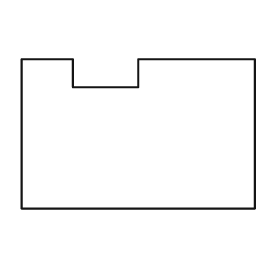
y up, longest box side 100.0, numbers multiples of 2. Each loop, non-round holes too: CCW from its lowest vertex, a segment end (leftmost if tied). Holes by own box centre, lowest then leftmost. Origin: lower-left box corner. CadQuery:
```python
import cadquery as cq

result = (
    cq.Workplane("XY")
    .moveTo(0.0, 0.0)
    .lineTo(100.0, 0.0)
    .lineTo(100.0, 64.0)
    .lineTo(50.0, 64.0)
    .lineTo(50.0, 52.0)
    .lineTo(22.0, 52.0)
    .lineTo(22.0, 64.0)
    .lineTo(0.0, 64.0)
    .close()
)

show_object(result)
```